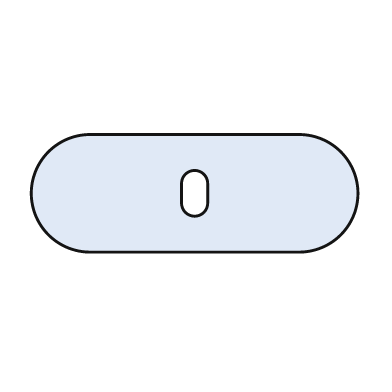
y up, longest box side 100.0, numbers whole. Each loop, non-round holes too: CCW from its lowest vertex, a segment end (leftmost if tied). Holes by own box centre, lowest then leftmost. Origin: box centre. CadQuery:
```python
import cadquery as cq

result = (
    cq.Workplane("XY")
    .moveTo(-32.0, -18.0)
    .lineTo(32.0, -18.0)
    .threePointArc((50.0, 0.0), (32.0, 18.0))
    .lineTo(-32.0, 18.0)
    .threePointArc((-50.0, 0.0), (-32.0, -18.0))
    .close()
    .moveTo(-4.0, -3.0)
    .threePointArc((0.0, -7.0), (4.0, -3.0))
    .lineTo(4.0, 3.0)
    .threePointArc((0.0, 7.0), (-4.0, 3.0))
    .close()
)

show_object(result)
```